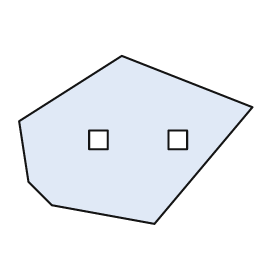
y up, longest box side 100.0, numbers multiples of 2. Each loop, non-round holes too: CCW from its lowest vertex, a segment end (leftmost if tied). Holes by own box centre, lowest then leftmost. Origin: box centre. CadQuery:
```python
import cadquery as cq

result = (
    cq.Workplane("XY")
    .moveTo(8.0, -36.0)
    .lineTo(50.0, 14.0)
    .lineTo(-6.0, 36.0)
    .lineTo(-50.0, 8.0)
    .lineTo(-46.0, -18.0)
    .lineTo(-36.0, -28.0)
    .close()
    .moveTo(-20.0, -4.0)
    .lineTo(-12.0, -4.0)
    .lineTo(-12.0, 4.0)
    .lineTo(-20.0, 4.0)
    .close()
    .moveTo(14.0, -4.0)
    .lineTo(22.0, -4.0)
    .lineTo(22.0, 4.0)
    .lineTo(14.0, 4.0)
    .close()
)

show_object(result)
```